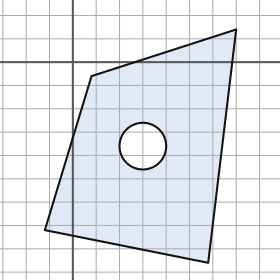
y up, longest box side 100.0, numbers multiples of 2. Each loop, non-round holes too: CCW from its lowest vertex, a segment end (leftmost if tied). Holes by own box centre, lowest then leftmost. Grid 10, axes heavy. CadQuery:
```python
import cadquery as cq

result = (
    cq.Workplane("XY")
    .moveTo(58.0, -86.0)
    .lineTo(70.0, 14.0)
    .lineTo(8.0, -6.0)
    .lineTo(-12.0, -72.0)
    .close()
    .moveTo(30.0, -36.0)
    .circle(10.0)
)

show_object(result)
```